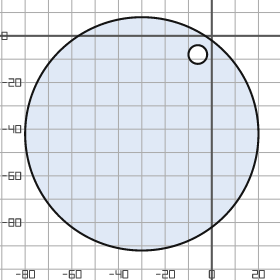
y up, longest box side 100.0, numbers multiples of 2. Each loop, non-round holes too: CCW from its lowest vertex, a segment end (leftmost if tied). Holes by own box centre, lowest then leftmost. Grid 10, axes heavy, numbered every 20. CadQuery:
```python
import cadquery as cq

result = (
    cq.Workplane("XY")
    .moveTo(-30.0, -42.0)
    .circle(50.0)
    .moveTo(-6.0, -8.0)
    .circle(4.0)
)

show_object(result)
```